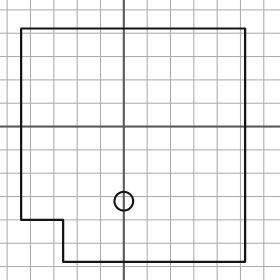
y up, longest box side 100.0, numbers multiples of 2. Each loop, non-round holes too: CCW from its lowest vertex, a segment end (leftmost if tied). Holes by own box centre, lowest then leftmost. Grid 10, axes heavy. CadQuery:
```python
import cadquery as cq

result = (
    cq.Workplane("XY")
    .moveTo(-26.0, -58.0)
    .lineTo(52.0, -58.0)
    .lineTo(52.0, 42.0)
    .lineTo(-44.0, 42.0)
    .lineTo(-44.0, -40.0)
    .lineTo(-26.0, -40.0)
    .close()
    .moveTo(0.0, -32.0)
    .circle(4.0)
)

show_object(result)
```